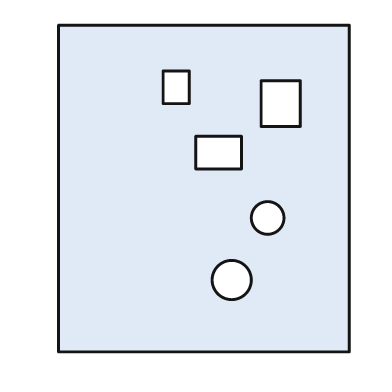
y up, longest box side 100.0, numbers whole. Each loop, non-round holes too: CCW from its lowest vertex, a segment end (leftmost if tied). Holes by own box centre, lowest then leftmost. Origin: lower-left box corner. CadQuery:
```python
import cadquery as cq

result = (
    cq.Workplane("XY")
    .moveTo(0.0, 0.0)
    .lineTo(89.0, 0.0)
    .lineTo(89.0, 100.0)
    .lineTo(0.0, 100.0)
    .close()
    .moveTo(53.0, 22.0)
    .circle(6.0)
    .moveTo(64.0, 41.0)
    .circle(5.0)
    .moveTo(42.0, 56.0)
    .lineTo(56.0, 56.0)
    .lineTo(56.0, 66.0)
    .lineTo(42.0, 66.0)
    .close()
    .moveTo(62.0, 69.0)
    .lineTo(74.0, 69.0)
    .lineTo(74.0, 83.0)
    .lineTo(62.0, 83.0)
    .close()
    .moveTo(32.0, 76.0)
    .lineTo(40.0, 76.0)
    .lineTo(40.0, 86.0)
    .lineTo(32.0, 86.0)
    .close()
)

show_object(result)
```